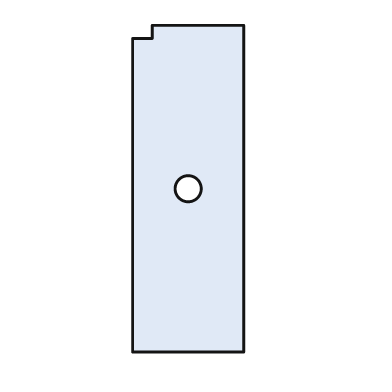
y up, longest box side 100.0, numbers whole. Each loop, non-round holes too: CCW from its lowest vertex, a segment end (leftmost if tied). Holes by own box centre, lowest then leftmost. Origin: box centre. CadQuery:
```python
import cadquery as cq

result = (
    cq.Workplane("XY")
    .moveTo(-17.0, -50.0)
    .lineTo(17.0, -50.0)
    .lineTo(17.0, 50.0)
    .lineTo(-11.0, 50.0)
    .lineTo(-11.0, 46.0)
    .lineTo(-17.0, 46.0)
    .close()
    .moveTo(0.0, 0.0)
    .circle(4.0)
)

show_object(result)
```